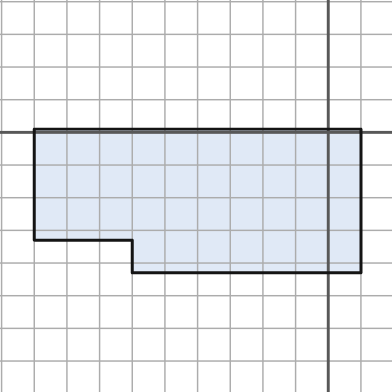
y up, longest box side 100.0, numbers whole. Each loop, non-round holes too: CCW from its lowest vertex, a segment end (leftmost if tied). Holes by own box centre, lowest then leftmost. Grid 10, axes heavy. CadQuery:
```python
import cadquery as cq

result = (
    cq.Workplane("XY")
    .moveTo(-60.0, -43.0)
    .lineTo(10.0, -43.0)
    .lineTo(10.0, 1.0)
    .lineTo(-90.0, 1.0)
    .lineTo(-90.0, -33.0)
    .lineTo(-60.0, -33.0)
    .close()
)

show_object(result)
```